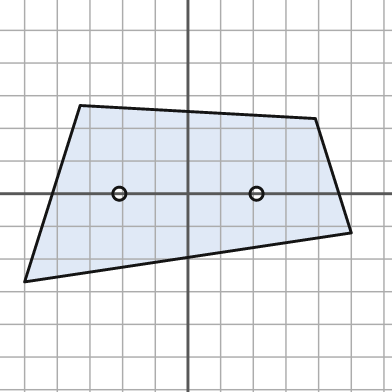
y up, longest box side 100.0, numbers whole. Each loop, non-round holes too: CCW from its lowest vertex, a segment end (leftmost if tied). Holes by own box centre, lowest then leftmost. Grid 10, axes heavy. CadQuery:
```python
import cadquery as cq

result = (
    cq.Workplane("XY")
    .moveTo(-50.0, -27.0)
    .lineTo(50.0, -12.0)
    .lineTo(39.0, 23.0)
    .lineTo(-33.0, 27.0)
    .close()
    .moveTo(-21.0, 0.0)
    .circle(2.0)
    .moveTo(21.0, 0.0)
    .circle(2.0)
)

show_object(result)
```